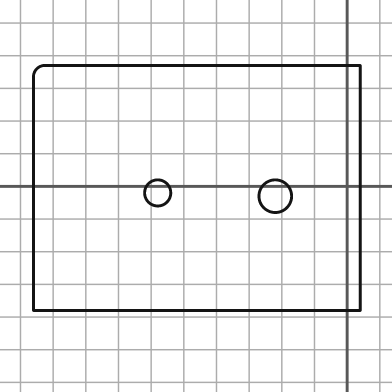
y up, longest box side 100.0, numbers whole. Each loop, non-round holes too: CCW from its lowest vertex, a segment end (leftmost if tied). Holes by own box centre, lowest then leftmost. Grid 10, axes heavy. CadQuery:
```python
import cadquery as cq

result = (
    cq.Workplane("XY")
    .moveTo(-96.0, -38.0)
    .lineTo(4.0, -38.0)
    .lineTo(4.0, 37.0)
    .lineTo(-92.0, 37.0)
    .threePointArc((-95.0, 36.0), (-96.0, 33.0))
    .close()
    .moveTo(-22.0, -3.0)
    .circle(5.0)
    .moveTo(-58.0, -2.0)
    .circle(4.0)
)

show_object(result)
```